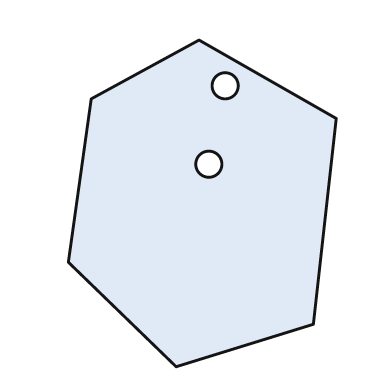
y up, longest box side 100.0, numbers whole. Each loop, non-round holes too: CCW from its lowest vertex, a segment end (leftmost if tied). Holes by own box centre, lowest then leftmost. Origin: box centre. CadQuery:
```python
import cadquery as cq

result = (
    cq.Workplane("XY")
    .moveTo(-8.0, -50.0)
    .lineTo(34.0, -37.0)
    .lineTo(41.0, 26.0)
    .lineTo(-1.0, 50.0)
    .lineTo(-34.0, 32.0)
    .lineTo(-41.0, -18.0)
    .close()
    .moveTo(2.0, 12.0)
    .circle(4.0)
    .moveTo(7.0, 36.0)
    .circle(4.0)
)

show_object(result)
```